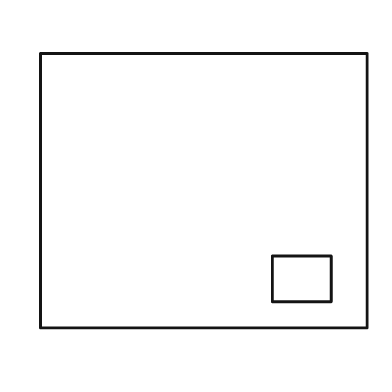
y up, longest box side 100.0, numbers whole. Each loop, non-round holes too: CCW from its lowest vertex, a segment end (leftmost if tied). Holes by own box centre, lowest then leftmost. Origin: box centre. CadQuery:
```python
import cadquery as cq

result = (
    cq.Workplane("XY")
    .moveTo(-50.0, -42.0)
    .lineTo(50.0, -42.0)
    .lineTo(50.0, 42.0)
    .lineTo(-50.0, 42.0)
    .close()
    .moveTo(21.0, -34.0)
    .lineTo(39.0, -34.0)
    .lineTo(39.0, -20.0)
    .lineTo(21.0, -20.0)
    .close()
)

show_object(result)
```